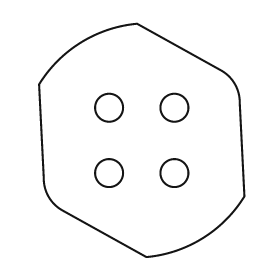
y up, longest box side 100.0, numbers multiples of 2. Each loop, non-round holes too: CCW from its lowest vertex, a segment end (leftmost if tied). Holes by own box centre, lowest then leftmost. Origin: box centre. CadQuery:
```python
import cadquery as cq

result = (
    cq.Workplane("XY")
    .moveTo(2.0, -50.0)
    .threePointArc((26.0, -42.0), (44.0, -24.0))
    .lineTo(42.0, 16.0)
    .threePointArc((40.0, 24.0), (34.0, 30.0))
    .lineTo(-2.0, 50.0)
    .threePointArc((-26.0, 42.0), (-44.0, 24.0))
    .lineTo(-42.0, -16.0)
    .threePointArc((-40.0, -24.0), (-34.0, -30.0))
    .close()
    .moveTo(-14.0, -14.0)
    .circle(6.0)
    .moveTo(14.0, -14.0)
    .circle(6.0)
    .moveTo(-14.0, 14.0)
    .circle(6.0)
    .moveTo(14.0, 14.0)
    .circle(6.0)
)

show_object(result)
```